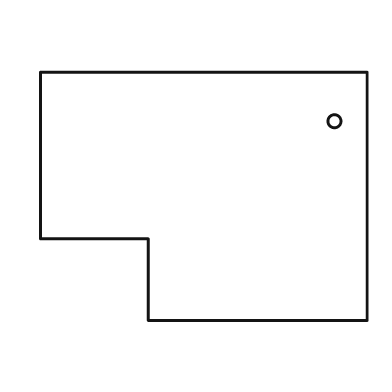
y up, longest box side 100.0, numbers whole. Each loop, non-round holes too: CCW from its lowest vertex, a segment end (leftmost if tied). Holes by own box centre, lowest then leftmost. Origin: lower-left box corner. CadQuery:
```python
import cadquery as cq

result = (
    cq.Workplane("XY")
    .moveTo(33.0, 0.0)
    .lineTo(100.0, 0.0)
    .lineTo(100.0, 76.0)
    .lineTo(0.0, 76.0)
    .lineTo(0.0, 25.0)
    .lineTo(33.0, 25.0)
    .close()
    .moveTo(90.0, 61.0)
    .circle(2.0)
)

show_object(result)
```